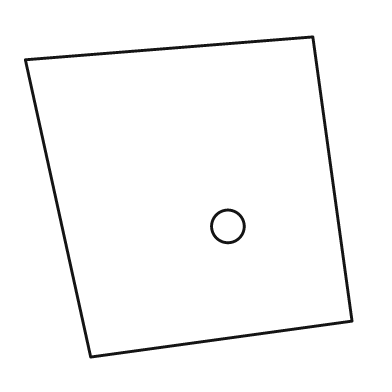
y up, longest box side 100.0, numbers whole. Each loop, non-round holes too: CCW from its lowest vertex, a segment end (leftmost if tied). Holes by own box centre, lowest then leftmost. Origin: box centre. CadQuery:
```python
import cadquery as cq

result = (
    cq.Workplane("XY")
    .moveTo(-30.0, -49.0)
    .lineTo(50.0, -38.0)
    .lineTo(38.0, 49.0)
    .lineTo(-50.0, 42.0)
    .close()
    .moveTo(12.0, -9.0)
    .circle(5.0)
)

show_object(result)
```